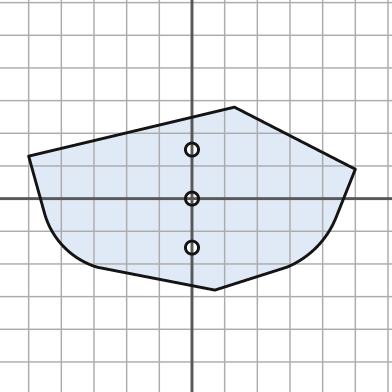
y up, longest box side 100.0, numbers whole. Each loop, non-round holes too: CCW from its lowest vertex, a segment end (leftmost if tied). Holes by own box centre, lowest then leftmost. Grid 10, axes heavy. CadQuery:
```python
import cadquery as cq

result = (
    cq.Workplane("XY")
    .moveTo(7.0, -28.0)
    .lineTo(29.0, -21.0)
    .threePointArc((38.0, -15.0), (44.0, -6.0))
    .lineTo(50.0, 9.0)
    .lineTo(13.0, 28.0)
    .lineTo(-50.0, 13.0)
    .lineTo(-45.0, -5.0)
    .threePointArc((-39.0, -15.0), (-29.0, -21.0))
    .close()
    .moveTo(0.0, -15.0)
    .circle(2.0)
    .moveTo(0.0, 0.0)
    .circle(2.0)
    .moveTo(0.0, 15.0)
    .circle(2.0)
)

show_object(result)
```